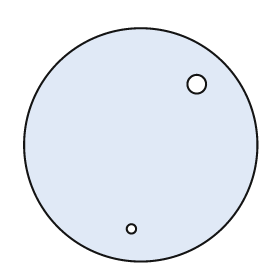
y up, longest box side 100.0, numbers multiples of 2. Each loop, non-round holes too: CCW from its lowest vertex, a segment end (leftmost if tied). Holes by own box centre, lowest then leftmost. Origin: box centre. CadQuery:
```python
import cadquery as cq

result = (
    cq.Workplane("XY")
    .moveTo(0.0, 0.0)
    .circle(50.0)
    .moveTo(-4.0, -36.0)
    .circle(2.0)
    .moveTo(24.0, 26.0)
    .circle(4.0)
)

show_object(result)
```